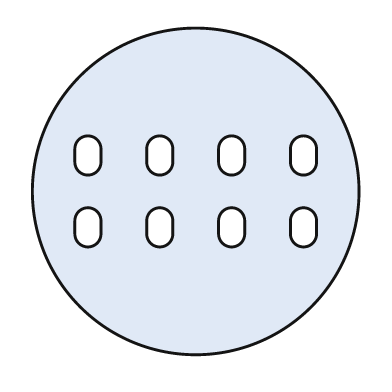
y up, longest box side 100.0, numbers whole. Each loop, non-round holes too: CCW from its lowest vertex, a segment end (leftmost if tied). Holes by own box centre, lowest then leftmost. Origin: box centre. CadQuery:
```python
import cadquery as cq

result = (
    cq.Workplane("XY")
    .moveTo(0.0, 0.0)
    .circle(50.0)
    .moveTo(-37.0, -13.0)
    .threePointArc((-33.0, -17.0), (-29.0, -13.0))
    .lineTo(-29.0, -9.0)
    .threePointArc((-33.0, -5.0), (-37.0, -9.0))
    .close()
    .moveTo(-15.0, -13.0)
    .threePointArc((-11.0, -17.0), (-7.0, -13.0))
    .lineTo(-7.0, -9.0)
    .threePointArc((-11.0, -5.0), (-15.0, -9.0))
    .close()
    .moveTo(7.0, -13.0)
    .threePointArc((11.0, -17.0), (15.0, -13.0))
    .lineTo(15.0, -9.0)
    .threePointArc((11.0, -5.0), (7.0, -9.0))
    .close()
    .moveTo(29.0, -13.0)
    .threePointArc((33.0, -17.0), (37.0, -13.0))
    .lineTo(37.0, -9.0)
    .threePointArc((33.0, -5.0), (29.0, -9.0))
    .close()
    .moveTo(-37.0, 9.0)
    .threePointArc((-33.0, 5.0), (-29.0, 9.0))
    .lineTo(-29.0, 13.0)
    .threePointArc((-33.0, 17.0), (-37.0, 13.0))
    .close()
    .moveTo(-15.0, 9.0)
    .threePointArc((-11.0, 5.0), (-7.0, 9.0))
    .lineTo(-7.0, 13.0)
    .threePointArc((-11.0, 17.0), (-15.0, 13.0))
    .close()
    .moveTo(7.0, 9.0)
    .threePointArc((11.0, 5.0), (15.0, 9.0))
    .lineTo(15.0, 13.0)
    .threePointArc((11.0, 17.0), (7.0, 13.0))
    .close()
    .moveTo(29.0, 9.0)
    .threePointArc((33.0, 5.0), (37.0, 9.0))
    .lineTo(37.0, 13.0)
    .threePointArc((33.0, 17.0), (29.0, 13.0))
    .close()
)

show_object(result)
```